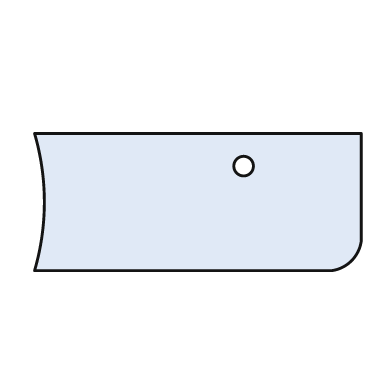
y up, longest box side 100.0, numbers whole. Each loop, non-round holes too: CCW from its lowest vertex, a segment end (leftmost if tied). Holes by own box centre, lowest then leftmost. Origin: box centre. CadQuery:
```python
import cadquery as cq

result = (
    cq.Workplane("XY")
    .moveTo(-50.0, -21.0)
    .lineTo(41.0, -21.0)
    .threePointArc((47.0, -18.0), (50.0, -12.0))
    .lineTo(50.0, 21.0)
    .lineTo(-50.0, 21.0)
    .threePointArc((-47.0, 0.0), (-50.0, -21.0))
    .close()
    .moveTo(14.0, 11.0)
    .circle(3.0)
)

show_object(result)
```